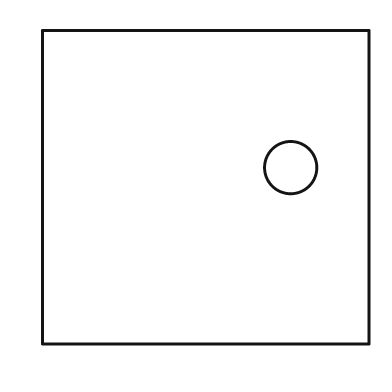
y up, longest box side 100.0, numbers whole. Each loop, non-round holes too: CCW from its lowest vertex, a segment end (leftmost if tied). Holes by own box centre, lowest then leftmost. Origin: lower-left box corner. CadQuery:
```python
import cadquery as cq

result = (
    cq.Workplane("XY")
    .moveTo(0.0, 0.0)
    .lineTo(100.0, 0.0)
    .lineTo(100.0, 96.0)
    .lineTo(0.0, 96.0)
    .close()
    .moveTo(76.0, 54.0)
    .circle(8.0)
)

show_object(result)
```